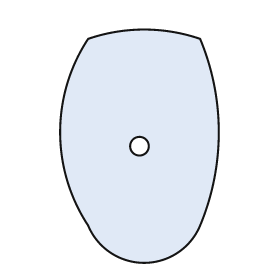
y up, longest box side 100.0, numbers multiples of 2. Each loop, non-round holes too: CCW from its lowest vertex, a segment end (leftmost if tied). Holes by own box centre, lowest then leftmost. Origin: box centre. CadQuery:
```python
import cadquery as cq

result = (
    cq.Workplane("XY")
    .moveTo(-22.0, -34.0)
    .threePointArc((2.0, -50.0), (26.0, -34.0))
    .threePointArc((34.0, 6.0), (26.0, 46.0))
    .threePointArc((2.0, 50.0), (-22.0, 46.0))
    .threePointArc((-34.0, 6.0), (-22.0, -34.0))
    .close()
    .moveTo(0.0, 0.0)
    .circle(4.0)
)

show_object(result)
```